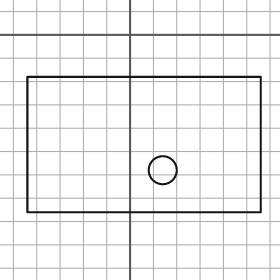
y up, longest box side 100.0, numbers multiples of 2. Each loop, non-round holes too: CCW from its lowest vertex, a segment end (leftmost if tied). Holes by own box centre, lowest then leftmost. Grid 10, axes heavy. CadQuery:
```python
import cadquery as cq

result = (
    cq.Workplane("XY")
    .moveTo(-44.0, -76.0)
    .lineTo(56.0, -76.0)
    .lineTo(56.0, -18.0)
    .lineTo(-44.0, -18.0)
    .close()
    .moveTo(14.0, -58.0)
    .circle(6.0)
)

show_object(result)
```